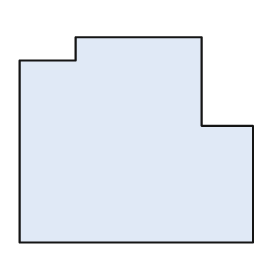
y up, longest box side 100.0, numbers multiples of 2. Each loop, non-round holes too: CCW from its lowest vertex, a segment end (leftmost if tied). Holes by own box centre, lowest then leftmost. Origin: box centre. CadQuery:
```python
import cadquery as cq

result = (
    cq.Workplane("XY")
    .moveTo(-50.0, -44.0)
    .lineTo(50.0, -44.0)
    .lineTo(50.0, 6.0)
    .lineTo(28.0, 6.0)
    .lineTo(28.0, 44.0)
    .lineTo(-26.0, 44.0)
    .lineTo(-26.0, 34.0)
    .lineTo(-50.0, 34.0)
    .close()
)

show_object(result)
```